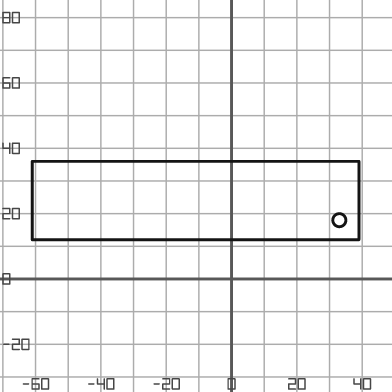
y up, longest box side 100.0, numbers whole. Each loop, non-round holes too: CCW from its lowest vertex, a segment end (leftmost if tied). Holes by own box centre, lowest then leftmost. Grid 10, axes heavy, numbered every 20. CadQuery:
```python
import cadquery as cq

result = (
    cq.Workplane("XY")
    .moveTo(-61.0, 12.0)
    .lineTo(39.0, 12.0)
    .lineTo(39.0, 36.0)
    .lineTo(-61.0, 36.0)
    .close()
    .moveTo(33.0, 18.0)
    .circle(2.0)
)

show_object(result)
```